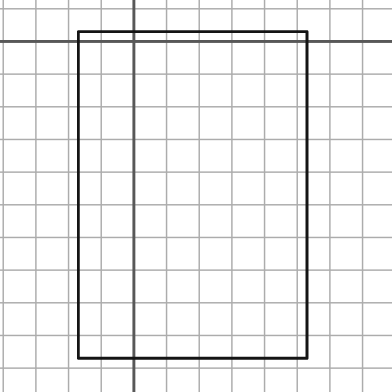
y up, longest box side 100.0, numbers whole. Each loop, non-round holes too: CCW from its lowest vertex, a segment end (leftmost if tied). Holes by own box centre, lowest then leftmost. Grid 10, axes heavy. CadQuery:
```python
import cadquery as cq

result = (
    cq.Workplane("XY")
    .moveTo(-17.0, -97.0)
    .lineTo(53.0, -97.0)
    .lineTo(53.0, 3.0)
    .lineTo(-17.0, 3.0)
    .close()
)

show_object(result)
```